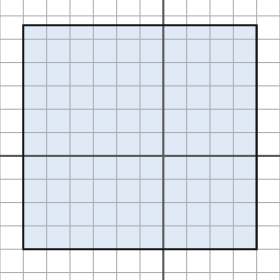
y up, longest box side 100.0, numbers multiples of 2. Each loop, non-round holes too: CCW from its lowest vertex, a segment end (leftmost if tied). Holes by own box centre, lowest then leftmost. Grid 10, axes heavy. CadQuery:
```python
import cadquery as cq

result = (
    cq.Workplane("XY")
    .moveTo(-60.0, -40.0)
    .lineTo(40.0, -40.0)
    .lineTo(40.0, 56.0)
    .lineTo(-60.0, 56.0)
    .close()
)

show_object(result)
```